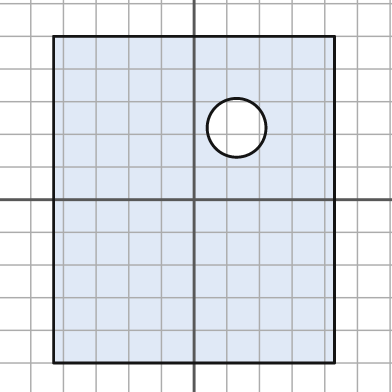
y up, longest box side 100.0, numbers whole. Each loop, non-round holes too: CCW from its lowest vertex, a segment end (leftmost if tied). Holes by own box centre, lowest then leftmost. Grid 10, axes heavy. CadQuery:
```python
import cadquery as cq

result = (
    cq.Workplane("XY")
    .moveTo(-43.0, -50.0)
    .lineTo(43.0, -50.0)
    .lineTo(43.0, 50.0)
    .lineTo(-43.0, 50.0)
    .close()
    .moveTo(13.0, 22.0)
    .circle(9.0)
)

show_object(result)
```